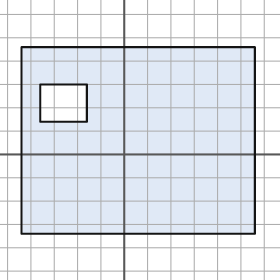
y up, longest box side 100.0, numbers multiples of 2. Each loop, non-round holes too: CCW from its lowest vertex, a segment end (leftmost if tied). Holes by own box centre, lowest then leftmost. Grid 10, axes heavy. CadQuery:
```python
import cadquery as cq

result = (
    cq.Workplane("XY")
    .moveTo(-44.0, -34.0)
    .lineTo(56.0, -34.0)
    .lineTo(56.0, 46.0)
    .lineTo(-44.0, 46.0)
    .close()
    .moveTo(-36.0, 14.0)
    .lineTo(-16.0, 14.0)
    .lineTo(-16.0, 30.0)
    .lineTo(-36.0, 30.0)
    .close()
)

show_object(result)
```